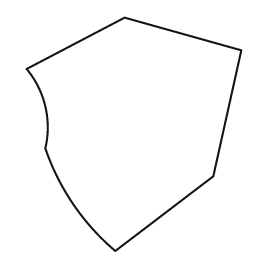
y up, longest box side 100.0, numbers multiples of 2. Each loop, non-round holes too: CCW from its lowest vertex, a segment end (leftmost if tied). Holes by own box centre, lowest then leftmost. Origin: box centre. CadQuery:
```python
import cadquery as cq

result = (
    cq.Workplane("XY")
    .moveTo(-8.0, -50.0)
    .lineTo(34.0, -18.0)
    .lineTo(46.0, 36.0)
    .lineTo(-4.0, 50.0)
    .lineTo(-46.0, 28.0)
    .threePointArc((-38.0, 12.0), (-38.0, -6.0))
    .threePointArc((-26.0, -30.0), (-8.0, -50.0))
    .close()
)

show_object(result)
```